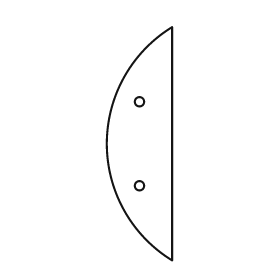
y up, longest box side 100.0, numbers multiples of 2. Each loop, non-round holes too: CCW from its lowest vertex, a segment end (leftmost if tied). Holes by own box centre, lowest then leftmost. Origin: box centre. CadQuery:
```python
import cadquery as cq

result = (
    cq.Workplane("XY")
    .moveTo(14.0, -50.0)
    .lineTo(14.0, 50.0)
    .threePointArc((-14.0, 0.0), (14.0, -50.0))
    .close()
    .moveTo(0.0, -18.0)
    .circle(2.0)
    .moveTo(0.0, 18.0)
    .circle(2.0)
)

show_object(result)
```